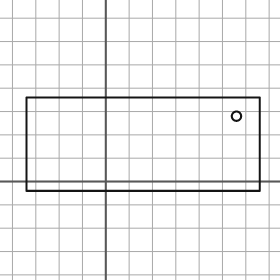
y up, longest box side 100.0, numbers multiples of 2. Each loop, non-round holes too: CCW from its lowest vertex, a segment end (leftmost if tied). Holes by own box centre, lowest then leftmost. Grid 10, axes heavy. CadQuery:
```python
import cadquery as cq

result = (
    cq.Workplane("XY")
    .moveTo(-34.0, -4.0)
    .lineTo(66.0, -4.0)
    .lineTo(66.0, 36.0)
    .lineTo(-34.0, 36.0)
    .close()
    .moveTo(56.0, 28.0)
    .circle(2.0)
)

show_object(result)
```